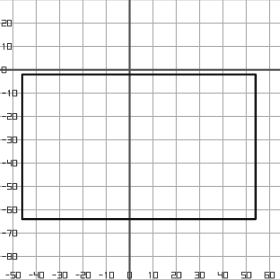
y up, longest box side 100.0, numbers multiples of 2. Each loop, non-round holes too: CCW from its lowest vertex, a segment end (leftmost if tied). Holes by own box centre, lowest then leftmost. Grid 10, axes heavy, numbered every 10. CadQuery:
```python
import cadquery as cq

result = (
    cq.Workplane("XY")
    .moveTo(-46.0, -64.0)
    .lineTo(54.0, -64.0)
    .lineTo(54.0, -2.0)
    .lineTo(-46.0, -2.0)
    .close()
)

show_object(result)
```